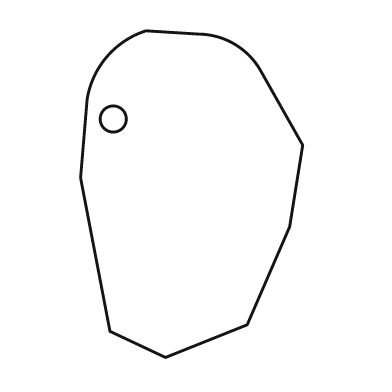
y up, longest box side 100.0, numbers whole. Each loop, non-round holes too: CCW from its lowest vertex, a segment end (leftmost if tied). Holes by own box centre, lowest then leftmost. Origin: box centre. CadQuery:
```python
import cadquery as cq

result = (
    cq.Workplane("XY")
    .moveTo(-8.0, -50.0)
    .lineTo(17.0, -40.0)
    .lineTo(30.0, -10.0)
    .lineTo(34.0, 15.0)
    .lineTo(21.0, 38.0)
    .threePointArc((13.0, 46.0), (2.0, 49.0))
    .lineTo(-14.0, 50.0)
    .threePointArc((-26.0, 42.0), (-32.0, 29.0))
    .lineTo(-34.0, 5.0)
    .lineTo(-25.0, -42.0)
    .close()
    .moveTo(-24.0, 23.0)
    .circle(4.0)
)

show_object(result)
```